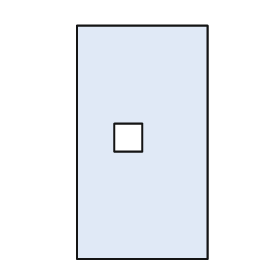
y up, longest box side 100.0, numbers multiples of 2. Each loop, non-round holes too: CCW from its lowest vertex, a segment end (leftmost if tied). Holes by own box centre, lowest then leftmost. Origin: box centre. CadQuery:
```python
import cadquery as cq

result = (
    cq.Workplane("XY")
    .moveTo(-28.0, -50.0)
    .lineTo(28.0, -50.0)
    .lineTo(28.0, 50.0)
    .lineTo(-28.0, 50.0)
    .close()
    .moveTo(-12.0, -4.0)
    .lineTo(0.0, -4.0)
    .lineTo(0.0, 8.0)
    .lineTo(-12.0, 8.0)
    .close()
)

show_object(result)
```